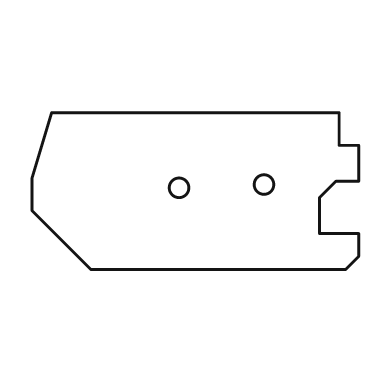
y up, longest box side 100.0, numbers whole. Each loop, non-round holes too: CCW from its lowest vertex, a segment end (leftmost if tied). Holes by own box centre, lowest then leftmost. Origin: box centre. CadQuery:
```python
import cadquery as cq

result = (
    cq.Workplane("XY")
    .moveTo(-32.0, -24.0)
    .lineTo(46.0, -24.0)
    .lineTo(50.0, -20.0)
    .lineTo(50.0, -13.0)
    .lineTo(38.0, -13.0)
    .lineTo(38.0, -2.0)
    .lineTo(43.0, 3.0)
    .lineTo(50.0, 3.0)
    .lineTo(50.0, 14.0)
    .lineTo(44.0, 14.0)
    .lineTo(44.0, 24.0)
    .lineTo(-44.0, 24.0)
    .lineTo(-50.0, 4.0)
    .lineTo(-50.0, -6.0)
    .close()
    .moveTo(-5.0, 1.0)
    .circle(3.0)
    .moveTo(21.0, 2.0)
    .circle(3.0)
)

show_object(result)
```